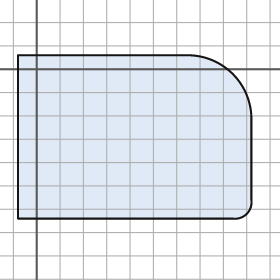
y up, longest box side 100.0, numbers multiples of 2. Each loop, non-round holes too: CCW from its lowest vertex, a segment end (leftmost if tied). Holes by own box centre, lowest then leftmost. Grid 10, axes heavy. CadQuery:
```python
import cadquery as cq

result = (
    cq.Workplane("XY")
    .moveTo(-8.0, -64.0)
    .lineTo(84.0, -64.0)
    .threePointArc((90.0, -62.0), (92.0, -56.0))
    .lineTo(92.0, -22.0)
    .threePointArc((84.0, -2.0), (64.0, 6.0))
    .lineTo(-8.0, 6.0)
    .close()
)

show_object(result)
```